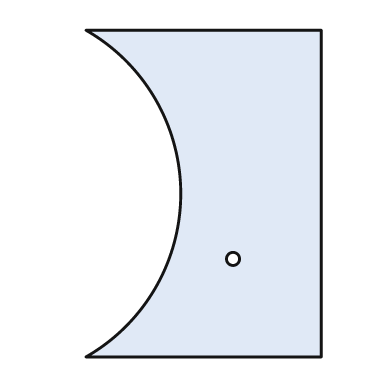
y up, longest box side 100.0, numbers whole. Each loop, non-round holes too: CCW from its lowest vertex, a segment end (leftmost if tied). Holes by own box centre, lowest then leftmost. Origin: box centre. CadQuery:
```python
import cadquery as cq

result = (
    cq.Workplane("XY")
    .moveTo(-36.0, -50.0)
    .lineTo(36.0, -50.0)
    .lineTo(36.0, 50.0)
    .lineTo(-36.0, 50.0)
    .threePointArc((-7.0, 0.0), (-36.0, -50.0))
    .close()
    .moveTo(9.0, -20.0)
    .circle(2.0)
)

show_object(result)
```